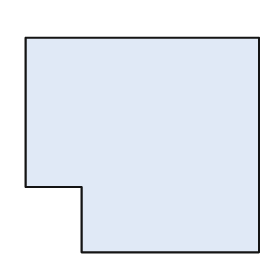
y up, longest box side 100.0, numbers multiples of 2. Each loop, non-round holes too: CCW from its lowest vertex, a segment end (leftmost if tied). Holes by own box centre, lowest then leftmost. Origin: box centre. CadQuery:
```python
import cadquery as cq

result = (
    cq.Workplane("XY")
    .moveTo(-26.0, -46.0)
    .lineTo(50.0, -46.0)
    .lineTo(50.0, 46.0)
    .lineTo(-50.0, 46.0)
    .lineTo(-50.0, -18.0)
    .lineTo(-26.0, -18.0)
    .close()
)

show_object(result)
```